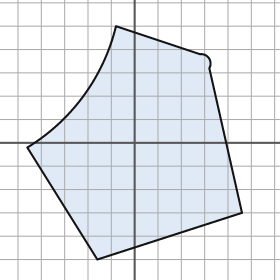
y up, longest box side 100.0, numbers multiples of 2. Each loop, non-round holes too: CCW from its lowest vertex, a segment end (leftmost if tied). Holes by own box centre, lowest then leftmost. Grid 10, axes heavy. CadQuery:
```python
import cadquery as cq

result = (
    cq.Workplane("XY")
    .moveTo(-16.0, -50.0)
    .lineTo(46.0, -30.0)
    .lineTo(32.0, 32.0)
    .threePointArc((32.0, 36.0), (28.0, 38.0))
    .lineTo(-8.0, 50.0)
    .threePointArc((-22.0, 20.0), (-46.0, -2.0))
    .close()
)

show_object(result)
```